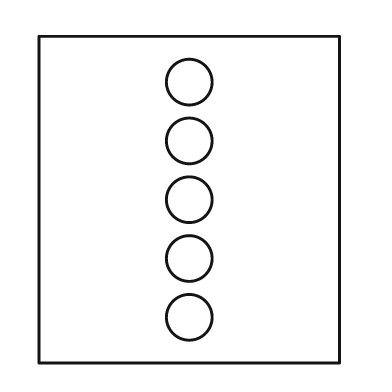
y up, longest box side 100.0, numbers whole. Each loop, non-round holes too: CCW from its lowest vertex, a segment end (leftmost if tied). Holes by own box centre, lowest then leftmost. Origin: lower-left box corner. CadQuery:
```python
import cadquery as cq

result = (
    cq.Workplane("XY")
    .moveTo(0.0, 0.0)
    .lineTo(92.0, 0.0)
    .lineTo(92.0, 100.0)
    .lineTo(0.0, 100.0)
    .close()
    .moveTo(46.0, 14.0)
    .circle(7.0)
    .moveTo(46.0, 32.0)
    .circle(7.0)
    .moveTo(46.0, 50.0)
    .circle(7.0)
    .moveTo(46.0, 68.0)
    .circle(7.0)
    .moveTo(46.0, 86.0)
    .circle(7.0)
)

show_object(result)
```